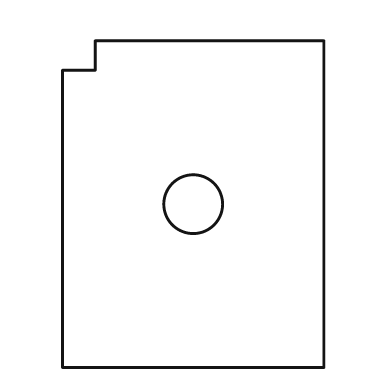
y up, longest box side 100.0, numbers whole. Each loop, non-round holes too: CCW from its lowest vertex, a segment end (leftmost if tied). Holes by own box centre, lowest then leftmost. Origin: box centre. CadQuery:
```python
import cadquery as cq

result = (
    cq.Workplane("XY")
    .moveTo(-40.0, -50.0)
    .lineTo(40.0, -50.0)
    .lineTo(40.0, 50.0)
    .lineTo(-30.0, 50.0)
    .lineTo(-30.0, 41.0)
    .lineTo(-40.0, 41.0)
    .close()
    .moveTo(0.0, 0.0)
    .circle(9.0)
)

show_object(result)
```